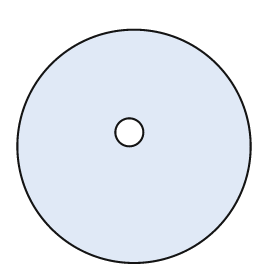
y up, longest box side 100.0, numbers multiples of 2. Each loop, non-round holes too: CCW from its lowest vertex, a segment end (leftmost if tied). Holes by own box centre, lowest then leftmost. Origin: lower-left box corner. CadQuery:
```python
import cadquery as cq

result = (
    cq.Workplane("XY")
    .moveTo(50.0, 50.0)
    .circle(50.0)
    .moveTo(48.0, 56.0)
    .circle(6.0)
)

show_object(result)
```